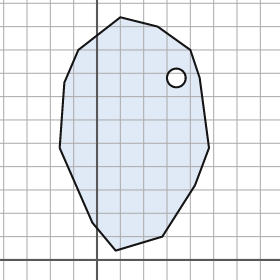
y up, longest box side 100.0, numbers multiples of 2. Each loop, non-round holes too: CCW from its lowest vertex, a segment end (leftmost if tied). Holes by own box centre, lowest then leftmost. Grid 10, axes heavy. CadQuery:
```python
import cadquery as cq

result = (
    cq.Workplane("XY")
    .moveTo(8.0, 4.0)
    .lineTo(28.0, 10.0)
    .lineTo(42.0, 32.0)
    .lineTo(48.0, 48.0)
    .lineTo(44.0, 78.0)
    .lineTo(40.0, 90.0)
    .lineTo(26.0, 100.0)
    .lineTo(10.0, 104.0)
    .lineTo(-8.0, 90.0)
    .lineTo(-14.0, 76.0)
    .lineTo(-16.0, 48.0)
    .lineTo(-2.0, 16.0)
    .close()
    .moveTo(34.0, 78.0)
    .circle(4.0)
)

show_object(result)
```